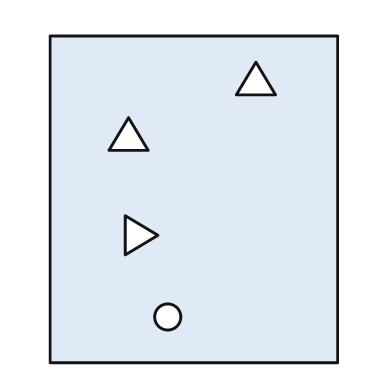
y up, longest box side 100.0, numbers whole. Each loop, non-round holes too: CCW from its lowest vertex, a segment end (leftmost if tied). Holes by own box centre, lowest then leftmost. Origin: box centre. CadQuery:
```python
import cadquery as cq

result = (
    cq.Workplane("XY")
    .moveTo(-44.0, -50.0)
    .lineTo(44.0, -50.0)
    .lineTo(44.0, 50.0)
    .lineTo(-44.0, 50.0)
    .close()
    .moveTo(-8.0, -36.0)
    .circle(4.0)
    .moveTo(-21.0, -17.0)
    .lineTo(-11.0, -11.0)
    .lineTo(-21.0, -5.0)
    .close()
    .moveTo(-26.0, 15.0)
    .lineTo(-14.0, 15.0)
    .lineTo(-20.0, 25.0)
    .close()
    .moveTo(13.0, 32.0)
    .lineTo(25.0, 32.0)
    .lineTo(19.0, 42.0)
    .close()
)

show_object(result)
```